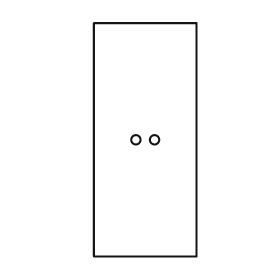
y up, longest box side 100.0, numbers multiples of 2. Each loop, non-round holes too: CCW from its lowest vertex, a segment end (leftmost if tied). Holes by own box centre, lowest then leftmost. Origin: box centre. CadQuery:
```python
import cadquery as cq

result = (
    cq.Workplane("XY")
    .moveTo(-22.0, -50.0)
    .lineTo(22.0, -50.0)
    .lineTo(22.0, 50.0)
    .lineTo(-22.0, 50.0)
    .close()
    .moveTo(-4.0, 0.0)
    .circle(2.0)
    .moveTo(4.0, 0.0)
    .circle(2.0)
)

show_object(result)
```